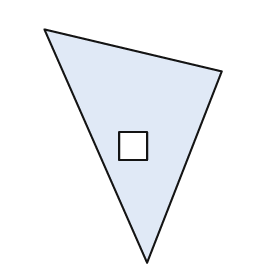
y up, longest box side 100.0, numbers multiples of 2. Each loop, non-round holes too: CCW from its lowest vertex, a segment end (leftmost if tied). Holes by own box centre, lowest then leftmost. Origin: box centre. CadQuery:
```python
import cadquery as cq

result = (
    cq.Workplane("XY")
    .moveTo(6.0, -50.0)
    .lineTo(38.0, 32.0)
    .lineTo(-38.0, 50.0)
    .close()
    .moveTo(-6.0, -6.0)
    .lineTo(6.0, -6.0)
    .lineTo(6.0, 6.0)
    .lineTo(-6.0, 6.0)
    .close()
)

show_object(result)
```